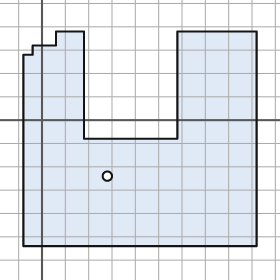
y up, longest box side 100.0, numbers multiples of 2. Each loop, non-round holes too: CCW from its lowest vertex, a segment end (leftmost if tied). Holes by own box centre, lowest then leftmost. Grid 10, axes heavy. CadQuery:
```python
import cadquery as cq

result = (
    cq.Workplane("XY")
    .moveTo(-8.0, -54.0)
    .lineTo(92.0, -54.0)
    .lineTo(92.0, 38.0)
    .lineTo(58.0, 38.0)
    .lineTo(58.0, -8.0)
    .lineTo(18.0, -8.0)
    .lineTo(18.0, 38.0)
    .lineTo(6.0, 38.0)
    .lineTo(6.0, 32.0)
    .lineTo(-4.0, 32.0)
    .lineTo(-4.0, 28.0)
    .lineTo(-8.0, 28.0)
    .close()
    .moveTo(28.0, -24.0)
    .circle(2.0)
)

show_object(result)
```